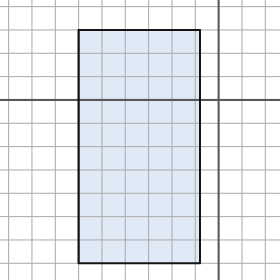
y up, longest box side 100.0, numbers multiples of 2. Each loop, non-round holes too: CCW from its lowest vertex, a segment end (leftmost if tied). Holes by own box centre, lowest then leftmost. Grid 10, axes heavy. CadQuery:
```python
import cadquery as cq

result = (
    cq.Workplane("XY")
    .moveTo(-60.0, -70.0)
    .lineTo(-8.0, -70.0)
    .lineTo(-8.0, 30.0)
    .lineTo(-60.0, 30.0)
    .close()
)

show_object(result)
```